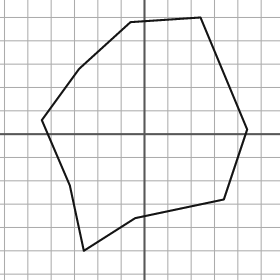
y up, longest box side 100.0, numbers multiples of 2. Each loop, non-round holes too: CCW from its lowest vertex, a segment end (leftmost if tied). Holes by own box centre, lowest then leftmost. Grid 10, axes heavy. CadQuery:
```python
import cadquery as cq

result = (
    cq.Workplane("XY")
    .moveTo(-26.0, -50.0)
    .lineTo(-4.0, -36.0)
    .lineTo(34.0, -28.0)
    .lineTo(44.0, 2.0)
    .lineTo(24.0, 50.0)
    .lineTo(-6.0, 48.0)
    .lineTo(-28.0, 28.0)
    .lineTo(-44.0, 6.0)
    .lineTo(-32.0, -22.0)
    .close()
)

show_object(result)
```